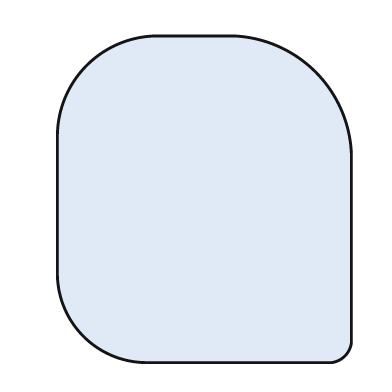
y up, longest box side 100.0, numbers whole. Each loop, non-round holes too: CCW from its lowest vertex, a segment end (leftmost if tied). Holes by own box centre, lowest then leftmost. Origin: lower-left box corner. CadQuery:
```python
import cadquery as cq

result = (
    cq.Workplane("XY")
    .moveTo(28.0, 0.0)
    .lineTo(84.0, 0.0)
    .threePointArc((88.0, 2.0), (90.0, 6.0))
    .lineTo(90.0, 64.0)
    .threePointArc((79.0, 89.0), (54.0, 100.0))
    .lineTo(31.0, 100.0)
    .threePointArc((9.0, 91.0), (0.0, 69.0))
    .lineTo(0.0, 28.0)
    .threePointArc((8.0, 8.0), (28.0, 0.0))
    .close()
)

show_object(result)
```